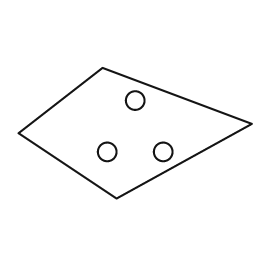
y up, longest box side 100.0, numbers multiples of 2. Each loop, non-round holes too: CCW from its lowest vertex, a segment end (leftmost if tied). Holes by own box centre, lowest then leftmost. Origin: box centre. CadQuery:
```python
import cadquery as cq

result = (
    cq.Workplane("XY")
    .moveTo(-8.0, -28.0)
    .lineTo(50.0, 4.0)
    .lineTo(-14.0, 28.0)
    .lineTo(-50.0, 0.0)
    .close()
    .moveTo(-12.0, -8.0)
    .circle(4.0)
    .moveTo(12.0, -8.0)
    .circle(4.0)
    .moveTo(0.0, 14.0)
    .circle(4.0)
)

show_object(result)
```